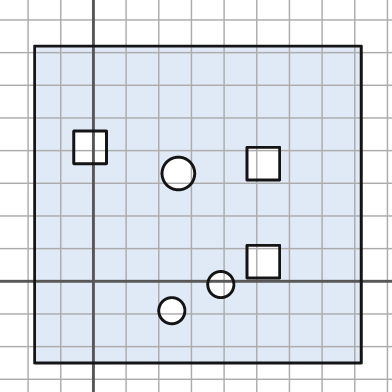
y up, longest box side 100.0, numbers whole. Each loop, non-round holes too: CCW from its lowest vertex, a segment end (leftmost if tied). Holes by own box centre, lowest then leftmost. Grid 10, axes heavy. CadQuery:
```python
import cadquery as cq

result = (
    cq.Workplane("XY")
    .moveTo(-18.0, -25.0)
    .lineTo(82.0, -25.0)
    .lineTo(82.0, 72.0)
    .lineTo(-18.0, 72.0)
    .close()
    .moveTo(24.0, -9.0)
    .circle(4.0)
    .moveTo(39.0, -1.0)
    .circle(4.0)
    .moveTo(47.0, 1.0)
    .lineTo(57.0, 1.0)
    .lineTo(57.0, 11.0)
    .lineTo(47.0, 11.0)
    .close()
    .moveTo(26.0, 33.0)
    .circle(5.0)
    .moveTo(47.0, 31.0)
    .lineTo(57.0, 31.0)
    .lineTo(57.0, 41.0)
    .lineTo(47.0, 41.0)
    .close()
    .moveTo(-6.0, 36.0)
    .lineTo(4.0, 36.0)
    .lineTo(4.0, 46.0)
    .lineTo(-6.0, 46.0)
    .close()
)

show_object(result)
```